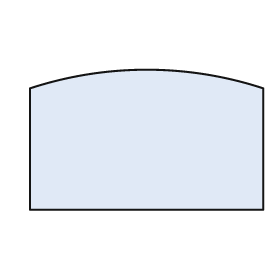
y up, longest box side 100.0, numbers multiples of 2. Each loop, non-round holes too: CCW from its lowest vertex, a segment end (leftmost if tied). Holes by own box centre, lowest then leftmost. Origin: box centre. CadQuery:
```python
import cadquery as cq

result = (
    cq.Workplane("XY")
    .moveTo(-50.0, -30.0)
    .lineTo(50.0, -30.0)
    .lineTo(50.0, 22.0)
    .threePointArc((0.0, 30.0), (-50.0, 22.0))
    .close()
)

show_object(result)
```